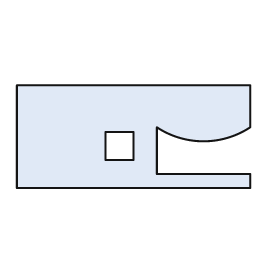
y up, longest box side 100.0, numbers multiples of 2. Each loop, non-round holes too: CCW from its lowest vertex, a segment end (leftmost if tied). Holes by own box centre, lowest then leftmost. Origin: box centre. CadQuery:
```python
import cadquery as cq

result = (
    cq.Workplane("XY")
    .moveTo(-50.0, -22.0)
    .lineTo(50.0, -22.0)
    .lineTo(50.0, -16.0)
    .lineTo(10.0, -16.0)
    .lineTo(10.0, 4.0)
    .threePointArc((30.0, -2.0), (50.0, 4.0))
    .lineTo(50.0, 22.0)
    .lineTo(-50.0, 22.0)
    .close()
    .moveTo(-12.0, -10.0)
    .lineTo(0.0, -10.0)
    .lineTo(0.0, 2.0)
    .lineTo(-12.0, 2.0)
    .close()
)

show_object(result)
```